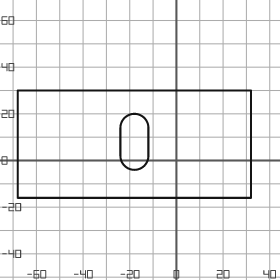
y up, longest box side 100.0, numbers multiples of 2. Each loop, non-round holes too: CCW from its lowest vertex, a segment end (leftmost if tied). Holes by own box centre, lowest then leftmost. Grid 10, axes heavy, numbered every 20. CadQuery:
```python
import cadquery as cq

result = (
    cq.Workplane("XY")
    .moveTo(-68.0, -16.0)
    .lineTo(32.0, -16.0)
    .lineTo(32.0, 30.0)
    .lineTo(-68.0, 30.0)
    .close()
    .moveTo(-24.0, 2.0)
    .threePointArc((-18.0, -4.0), (-12.0, 2.0))
    .lineTo(-12.0, 14.0)
    .threePointArc((-18.0, 20.0), (-24.0, 14.0))
    .close()
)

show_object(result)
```